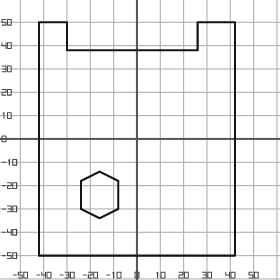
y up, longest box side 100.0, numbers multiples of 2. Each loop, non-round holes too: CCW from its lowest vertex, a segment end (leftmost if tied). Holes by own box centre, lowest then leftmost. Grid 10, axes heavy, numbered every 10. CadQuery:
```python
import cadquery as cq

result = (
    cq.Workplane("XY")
    .moveTo(-42.0, -50.0)
    .lineTo(42.0, -50.0)
    .lineTo(42.0, 50.0)
    .lineTo(26.0, 50.0)
    .lineTo(26.0, 38.0)
    .lineTo(-30.0, 38.0)
    .lineTo(-30.0, 50.0)
    .lineTo(-42.0, 50.0)
    .close()
    .moveTo(-16.0, -34.0)
    .lineTo(-8.0, -30.0)
    .lineTo(-8.0, -18.0)
    .lineTo(-16.0, -14.0)
    .lineTo(-24.0, -18.0)
    .lineTo(-24.0, -30.0)
    .close()
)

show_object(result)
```